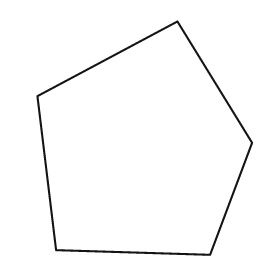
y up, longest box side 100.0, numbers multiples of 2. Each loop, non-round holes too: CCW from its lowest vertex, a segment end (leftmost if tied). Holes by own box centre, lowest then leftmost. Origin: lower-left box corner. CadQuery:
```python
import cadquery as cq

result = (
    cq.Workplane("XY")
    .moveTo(74.0, 0.0)
    .lineTo(92.0, 48.0)
    .lineTo(60.0, 100.0)
    .lineTo(0.0, 68.0)
    .lineTo(8.0, 2.0)
    .close()
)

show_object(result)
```